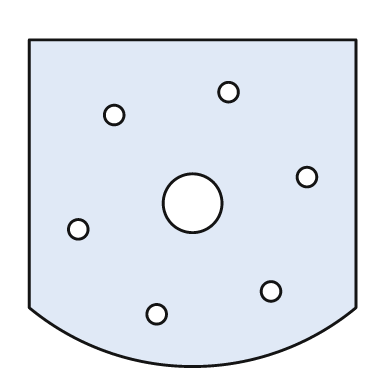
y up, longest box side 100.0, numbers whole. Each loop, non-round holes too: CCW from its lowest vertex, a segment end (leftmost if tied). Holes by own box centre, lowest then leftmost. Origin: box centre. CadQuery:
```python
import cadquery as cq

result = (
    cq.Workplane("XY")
    .moveTo(-50.0, -32.0)
    .threePointArc((0.0, -50.0), (50.0, -32.0))
    .lineTo(50.0, 50.0)
    .lineTo(-50.0, 50.0)
    .close()
    .moveTo(-11.0, -34.0)
    .circle(3.0)
    .moveTo(24.0, -27.0)
    .circle(3.0)
    .moveTo(-35.0, -8.0)
    .circle(3.0)
    .moveTo(0.0, 0.0)
    .circle(9.0)
    .moveTo(35.0, 8.0)
    .circle(3.0)
    .moveTo(-24.0, 27.0)
    .circle(3.0)
    .moveTo(11.0, 34.0)
    .circle(3.0)
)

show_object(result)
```